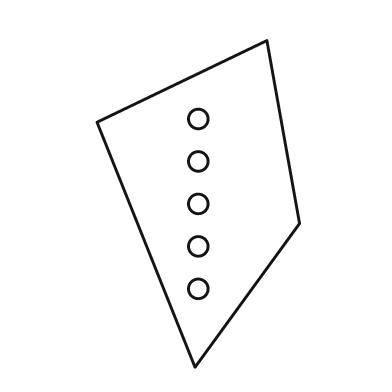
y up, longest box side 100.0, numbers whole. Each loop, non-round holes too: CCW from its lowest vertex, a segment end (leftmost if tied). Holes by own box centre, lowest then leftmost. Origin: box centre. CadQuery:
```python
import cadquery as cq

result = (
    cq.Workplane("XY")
    .moveTo(-1.0, -50.0)
    .lineTo(31.0, -6.0)
    .lineTo(21.0, 50.0)
    .lineTo(-31.0, 25.0)
    .close()
    .moveTo(0.0, -26.0)
    .circle(3.0)
    .moveTo(0.0, -13.0)
    .circle(3.0)
    .moveTo(0.0, 0.0)
    .circle(3.0)
    .moveTo(0.0, 13.0)
    .circle(3.0)
    .moveTo(0.0, 26.0)
    .circle(3.0)
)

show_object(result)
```